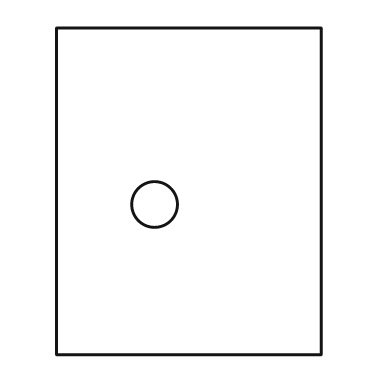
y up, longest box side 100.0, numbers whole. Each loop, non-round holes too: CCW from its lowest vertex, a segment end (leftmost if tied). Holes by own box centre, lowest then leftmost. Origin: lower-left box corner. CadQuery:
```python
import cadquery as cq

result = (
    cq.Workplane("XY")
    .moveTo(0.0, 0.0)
    .lineTo(81.0, 0.0)
    .lineTo(81.0, 100.0)
    .lineTo(0.0, 100.0)
    .close()
    .moveTo(30.0, 46.0)
    .circle(7.0)
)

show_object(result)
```